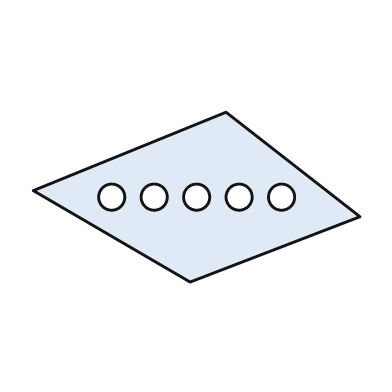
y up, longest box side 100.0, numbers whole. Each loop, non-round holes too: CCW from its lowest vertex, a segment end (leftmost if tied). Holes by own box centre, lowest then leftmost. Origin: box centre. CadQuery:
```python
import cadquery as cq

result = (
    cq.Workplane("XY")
    .moveTo(-2.0, -26.0)
    .lineTo(50.0, -6.0)
    .lineTo(9.0, 26.0)
    .lineTo(-50.0, 2.0)
    .close()
    .moveTo(-26.0, 0.0)
    .circle(4.0)
    .moveTo(-13.0, 0.0)
    .circle(4.0)
    .moveTo(0.0, 0.0)
    .circle(4.0)
    .moveTo(13.0, 0.0)
    .circle(4.0)
    .moveTo(26.0, 0.0)
    .circle(4.0)
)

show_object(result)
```